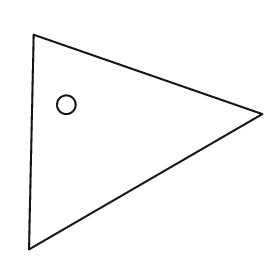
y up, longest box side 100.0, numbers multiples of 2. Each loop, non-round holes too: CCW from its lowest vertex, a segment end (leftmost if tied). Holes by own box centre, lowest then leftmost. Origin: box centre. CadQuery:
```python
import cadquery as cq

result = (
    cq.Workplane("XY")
    .moveTo(-50.0, -46.0)
    .lineTo(50.0, 12.0)
    .lineTo(-48.0, 46.0)
    .close()
    .moveTo(-34.0, 16.0)
    .circle(4.0)
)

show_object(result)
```